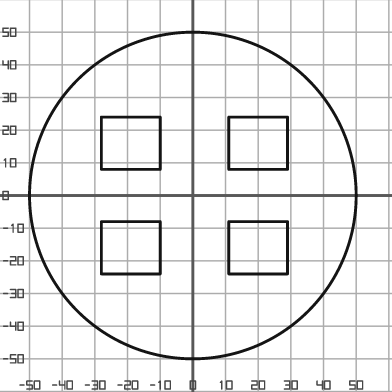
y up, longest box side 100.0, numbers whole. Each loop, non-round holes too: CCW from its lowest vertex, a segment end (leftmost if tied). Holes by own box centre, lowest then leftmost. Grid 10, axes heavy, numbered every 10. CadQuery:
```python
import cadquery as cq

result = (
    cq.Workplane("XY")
    .moveTo(0.0, 0.0)
    .circle(50.0)
    .moveTo(-28.0, -24.0)
    .lineTo(-10.0, -24.0)
    .lineTo(-10.0, -8.0)
    .lineTo(-28.0, -8.0)
    .close()
    .moveTo(11.0, -24.0)
    .lineTo(29.0, -24.0)
    .lineTo(29.0, -8.0)
    .lineTo(11.0, -8.0)
    .close()
    .moveTo(-28.0, 8.0)
    .lineTo(-10.0, 8.0)
    .lineTo(-10.0, 24.0)
    .lineTo(-28.0, 24.0)
    .close()
    .moveTo(11.0, 8.0)
    .lineTo(29.0, 8.0)
    .lineTo(29.0, 24.0)
    .lineTo(11.0, 24.0)
    .close()
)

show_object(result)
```